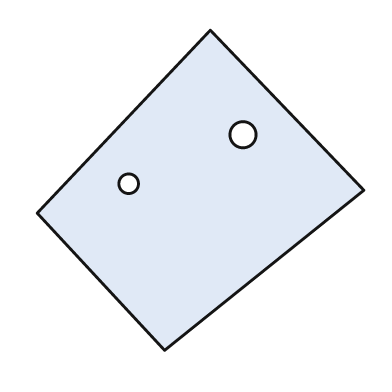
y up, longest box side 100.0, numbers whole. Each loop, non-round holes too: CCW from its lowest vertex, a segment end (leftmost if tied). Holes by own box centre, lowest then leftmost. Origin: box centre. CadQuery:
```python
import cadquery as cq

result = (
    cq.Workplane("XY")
    .moveTo(-11.0, -49.0)
    .lineTo(50.0, 0.0)
    .lineTo(3.0, 49.0)
    .lineTo(-50.0, -7.0)
    .close()
    .moveTo(-22.0, 2.0)
    .circle(3.0)
    .moveTo(13.0, 17.0)
    .circle(4.0)
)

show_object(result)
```